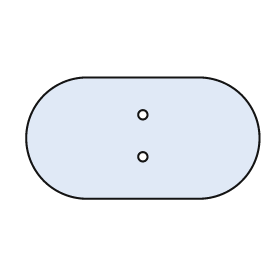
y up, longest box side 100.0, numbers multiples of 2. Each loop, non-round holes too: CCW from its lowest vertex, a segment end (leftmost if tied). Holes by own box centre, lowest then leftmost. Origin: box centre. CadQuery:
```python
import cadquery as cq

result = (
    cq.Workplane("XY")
    .moveTo(-24.0, -26.0)
    .lineTo(24.0, -26.0)
    .threePointArc((50.0, 0.0), (24.0, 26.0))
    .lineTo(-24.0, 26.0)
    .threePointArc((-50.0, 0.0), (-24.0, -26.0))
    .close()
    .moveTo(0.0, -8.0)
    .circle(2.0)
    .moveTo(0.0, 10.0)
    .circle(2.0)
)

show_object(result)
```